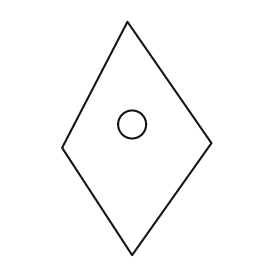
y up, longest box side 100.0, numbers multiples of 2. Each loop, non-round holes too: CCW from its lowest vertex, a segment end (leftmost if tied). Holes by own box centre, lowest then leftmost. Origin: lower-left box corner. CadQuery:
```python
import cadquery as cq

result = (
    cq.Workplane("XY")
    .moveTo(30.0, 0.0)
    .lineTo(64.0, 48.0)
    .lineTo(28.0, 100.0)
    .lineTo(0.0, 46.0)
    .close()
    .moveTo(30.0, 56.0)
    .circle(6.0)
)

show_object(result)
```